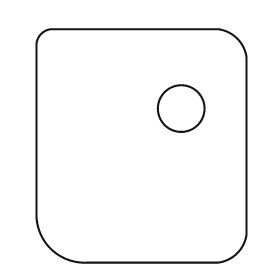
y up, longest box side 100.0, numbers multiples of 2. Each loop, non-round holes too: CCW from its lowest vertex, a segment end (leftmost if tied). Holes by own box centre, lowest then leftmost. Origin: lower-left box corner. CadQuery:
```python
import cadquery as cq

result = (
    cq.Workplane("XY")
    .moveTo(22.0, 0.0)
    .lineTo(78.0, 0.0)
    .threePointArc((86.0, 4.0), (90.0, 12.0))
    .lineTo(90.0, 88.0)
    .threePointArc((86.0, 96.0), (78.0, 100.0))
    .lineTo(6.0, 100.0)
    .threePointArc((2.0, 98.0), (0.0, 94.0))
    .lineTo(0.0, 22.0)
    .threePointArc((6.0, 6.0), (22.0, 0.0))
    .close()
    .moveTo(62.0, 66.0)
    .circle(10.0)
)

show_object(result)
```